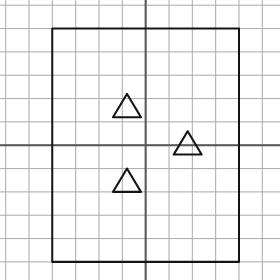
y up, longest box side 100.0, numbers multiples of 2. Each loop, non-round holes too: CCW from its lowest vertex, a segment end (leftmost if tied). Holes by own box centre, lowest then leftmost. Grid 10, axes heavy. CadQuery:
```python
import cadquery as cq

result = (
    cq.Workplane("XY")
    .moveTo(-40.0, -50.0)
    .lineTo(40.0, -50.0)
    .lineTo(40.0, 50.0)
    .lineTo(-40.0, 50.0)
    .close()
    .moveTo(-14.0, -20.0)
    .lineTo(-2.0, -20.0)
    .lineTo(-8.0, -10.0)
    .close()
    .moveTo(12.0, -4.0)
    .lineTo(24.0, -4.0)
    .lineTo(18.0, 6.0)
    .close()
    .moveTo(-14.0, 12.0)
    .lineTo(-2.0, 12.0)
    .lineTo(-8.0, 22.0)
    .close()
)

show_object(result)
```